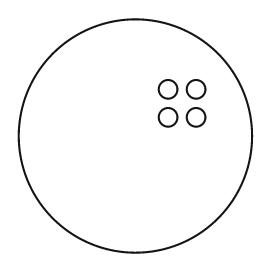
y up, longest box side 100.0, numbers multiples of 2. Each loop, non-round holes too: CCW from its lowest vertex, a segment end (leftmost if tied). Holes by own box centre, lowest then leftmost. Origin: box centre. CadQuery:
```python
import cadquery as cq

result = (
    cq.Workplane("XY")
    .moveTo(0.0, 0.0)
    .circle(50.0)
    .moveTo(14.0, 8.0)
    .circle(4.0)
    .moveTo(26.0, 8.0)
    .circle(4.0)
    .moveTo(14.0, 20.0)
    .circle(4.0)
    .moveTo(26.0, 20.0)
    .circle(4.0)
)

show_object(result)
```